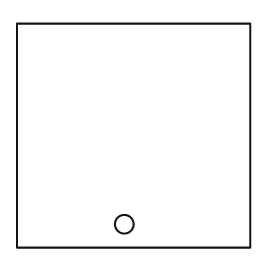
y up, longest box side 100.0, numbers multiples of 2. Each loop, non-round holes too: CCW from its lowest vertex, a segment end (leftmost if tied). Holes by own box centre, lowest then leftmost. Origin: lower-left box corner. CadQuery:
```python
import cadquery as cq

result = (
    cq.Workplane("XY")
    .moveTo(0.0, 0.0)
    .lineTo(100.0, 0.0)
    .lineTo(100.0, 96.0)
    .lineTo(0.0, 96.0)
    .close()
    .moveTo(46.0, 10.0)
    .circle(4.0)
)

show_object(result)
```